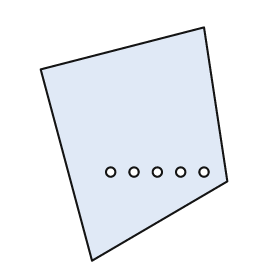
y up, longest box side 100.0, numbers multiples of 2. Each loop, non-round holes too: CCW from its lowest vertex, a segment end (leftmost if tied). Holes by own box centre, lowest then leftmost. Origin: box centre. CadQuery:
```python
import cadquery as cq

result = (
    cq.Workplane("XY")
    .moveTo(-18.0, -50.0)
    .lineTo(40.0, -16.0)
    .lineTo(30.0, 50.0)
    .lineTo(-40.0, 32.0)
    .close()
    .moveTo(-10.0, -12.0)
    .circle(2.0)
    .moveTo(0.0, -12.0)
    .circle(2.0)
    .moveTo(10.0, -12.0)
    .circle(2.0)
    .moveTo(20.0, -12.0)
    .circle(2.0)
    .moveTo(30.0, -12.0)
    .circle(2.0)
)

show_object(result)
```